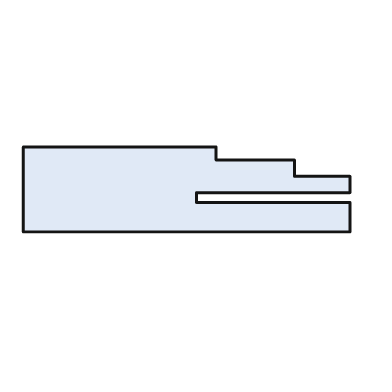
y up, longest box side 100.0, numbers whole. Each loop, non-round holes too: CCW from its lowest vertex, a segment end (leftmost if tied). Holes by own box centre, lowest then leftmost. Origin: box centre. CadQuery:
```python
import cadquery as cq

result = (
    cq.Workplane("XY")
    .moveTo(-50.0, -13.0)
    .lineTo(50.0, -13.0)
    .lineTo(50.0, -4.0)
    .lineTo(3.0, -4.0)
    .lineTo(3.0, -1.0)
    .lineTo(50.0, -1.0)
    .lineTo(50.0, 4.0)
    .lineTo(33.0, 4.0)
    .lineTo(33.0, 9.0)
    .lineTo(9.0, 9.0)
    .lineTo(9.0, 13.0)
    .lineTo(-50.0, 13.0)
    .close()
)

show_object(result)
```